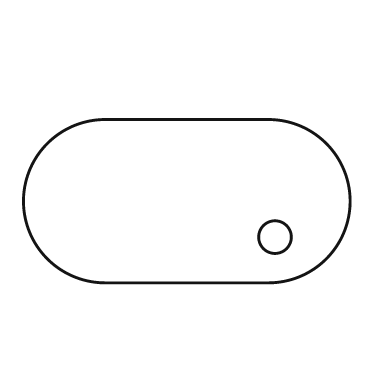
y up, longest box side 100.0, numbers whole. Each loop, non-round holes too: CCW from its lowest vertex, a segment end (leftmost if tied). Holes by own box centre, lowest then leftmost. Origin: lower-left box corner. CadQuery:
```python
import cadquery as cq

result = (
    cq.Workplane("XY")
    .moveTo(25.0, 0.0)
    .lineTo(75.0, 0.0)
    .threePointArc((100.0, 25.0), (75.0, 50.0))
    .lineTo(25.0, 50.0)
    .threePointArc((0.0, 25.0), (25.0, 0.0))
    .close()
    .moveTo(77.0, 14.0)
    .circle(5.0)
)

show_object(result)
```